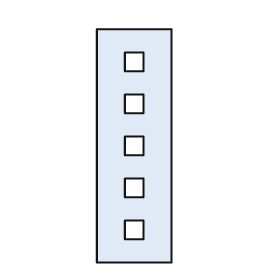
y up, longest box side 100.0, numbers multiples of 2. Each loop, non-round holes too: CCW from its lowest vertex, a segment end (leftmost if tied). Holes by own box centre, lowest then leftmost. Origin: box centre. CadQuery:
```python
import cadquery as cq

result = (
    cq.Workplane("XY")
    .moveTo(-16.0, -50.0)
    .lineTo(16.0, -50.0)
    .lineTo(16.0, 50.0)
    .lineTo(-16.0, 50.0)
    .close()
    .moveTo(-4.0, -40.0)
    .lineTo(4.0, -40.0)
    .lineTo(4.0, -32.0)
    .lineTo(-4.0, -32.0)
    .close()
    .moveTo(-4.0, -22.0)
    .lineTo(4.0, -22.0)
    .lineTo(4.0, -14.0)
    .lineTo(-4.0, -14.0)
    .close()
    .moveTo(-4.0, -4.0)
    .lineTo(4.0, -4.0)
    .lineTo(4.0, 4.0)
    .lineTo(-4.0, 4.0)
    .close()
    .moveTo(-4.0, 14.0)
    .lineTo(4.0, 14.0)
    .lineTo(4.0, 22.0)
    .lineTo(-4.0, 22.0)
    .close()
    .moveTo(-4.0, 32.0)
    .lineTo(4.0, 32.0)
    .lineTo(4.0, 40.0)
    .lineTo(-4.0, 40.0)
    .close()
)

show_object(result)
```